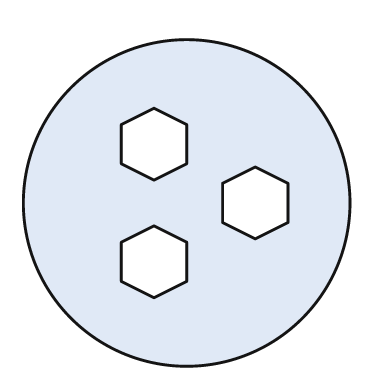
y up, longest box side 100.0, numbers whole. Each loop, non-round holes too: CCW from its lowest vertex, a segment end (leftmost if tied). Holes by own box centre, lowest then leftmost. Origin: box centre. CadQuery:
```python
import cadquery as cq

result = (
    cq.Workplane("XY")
    .moveTo(0.0, 0.0)
    .circle(50.0)
    .moveTo(-10.0, -29.0)
    .lineTo(0.0, -24.0)
    .lineTo(0.0, -12.0)
    .lineTo(-10.0, -7.0)
    .lineTo(-20.0, -12.0)
    .lineTo(-20.0, -24.0)
    .close()
    .moveTo(21.0, -11.0)
    .lineTo(31.0, -6.0)
    .lineTo(31.0, 6.0)
    .lineTo(21.0, 11.0)
    .lineTo(11.0, 6.0)
    .lineTo(11.0, -6.0)
    .close()
    .moveTo(-10.0, 7.0)
    .lineTo(0.0, 12.0)
    .lineTo(0.0, 24.0)
    .lineTo(-10.0, 29.0)
    .lineTo(-20.0, 24.0)
    .lineTo(-20.0, 12.0)
    .close()
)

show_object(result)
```